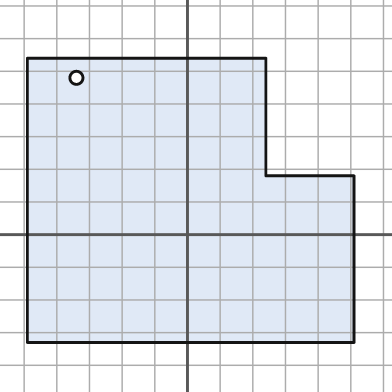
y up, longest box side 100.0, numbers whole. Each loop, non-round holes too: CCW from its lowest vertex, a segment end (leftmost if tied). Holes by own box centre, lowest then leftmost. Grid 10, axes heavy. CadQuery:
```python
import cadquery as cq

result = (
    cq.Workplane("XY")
    .moveTo(-49.0, -33.0)
    .lineTo(51.0, -33.0)
    .lineTo(51.0, 18.0)
    .lineTo(24.0, 18.0)
    .lineTo(24.0, 54.0)
    .lineTo(-49.0, 54.0)
    .close()
    .moveTo(-34.0, 48.0)
    .circle(2.0)
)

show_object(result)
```